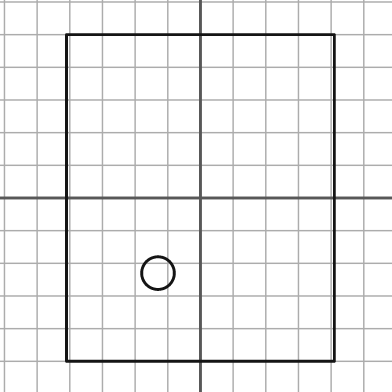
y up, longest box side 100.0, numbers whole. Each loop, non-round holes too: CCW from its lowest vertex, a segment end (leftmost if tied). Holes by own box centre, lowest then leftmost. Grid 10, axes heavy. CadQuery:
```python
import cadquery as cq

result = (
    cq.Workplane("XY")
    .moveTo(-41.0, -50.0)
    .lineTo(41.0, -50.0)
    .lineTo(41.0, 50.0)
    .lineTo(-41.0, 50.0)
    .close()
    .moveTo(-13.0, -23.0)
    .circle(5.0)
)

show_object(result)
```